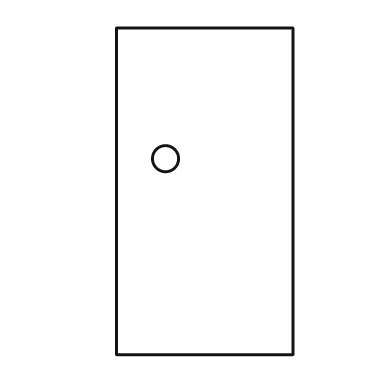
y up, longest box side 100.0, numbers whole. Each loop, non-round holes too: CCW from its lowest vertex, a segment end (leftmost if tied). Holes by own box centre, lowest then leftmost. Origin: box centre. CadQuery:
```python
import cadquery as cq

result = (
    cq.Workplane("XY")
    .moveTo(-27.0, -50.0)
    .lineTo(27.0, -50.0)
    .lineTo(27.0, 50.0)
    .lineTo(-27.0, 50.0)
    .close()
    .moveTo(-12.0, 10.0)
    .circle(4.0)
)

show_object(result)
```